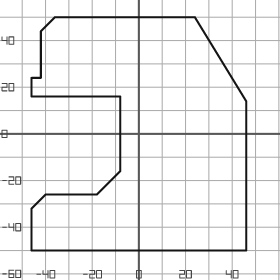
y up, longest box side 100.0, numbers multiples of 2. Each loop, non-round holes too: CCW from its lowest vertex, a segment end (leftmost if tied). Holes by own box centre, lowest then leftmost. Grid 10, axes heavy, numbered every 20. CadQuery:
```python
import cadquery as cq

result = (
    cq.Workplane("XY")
    .moveTo(-46.0, -50.0)
    .lineTo(46.0, -50.0)
    .lineTo(46.0, 14.0)
    .lineTo(24.0, 50.0)
    .lineTo(-36.0, 50.0)
    .lineTo(-42.0, 44.0)
    .lineTo(-42.0, 24.0)
    .lineTo(-46.0, 24.0)
    .lineTo(-46.0, 16.0)
    .lineTo(-8.0, 16.0)
    .lineTo(-8.0, -16.0)
    .lineTo(-18.0, -26.0)
    .lineTo(-40.0, -26.0)
    .lineTo(-46.0, -32.0)
    .close()
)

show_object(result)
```